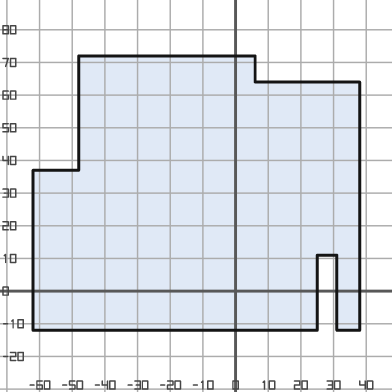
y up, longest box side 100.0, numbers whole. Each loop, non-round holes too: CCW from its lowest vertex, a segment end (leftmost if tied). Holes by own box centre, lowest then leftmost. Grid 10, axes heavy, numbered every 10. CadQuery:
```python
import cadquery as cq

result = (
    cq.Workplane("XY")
    .moveTo(-62.0, -12.0)
    .lineTo(25.0, -12.0)
    .lineTo(25.0, 11.0)
    .lineTo(31.0, 11.0)
    .lineTo(31.0, -12.0)
    .lineTo(38.0, -12.0)
    .lineTo(38.0, 64.0)
    .lineTo(6.0, 64.0)
    .lineTo(6.0, 72.0)
    .lineTo(-48.0, 72.0)
    .lineTo(-48.0, 37.0)
    .lineTo(-62.0, 37.0)
    .close()
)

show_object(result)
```